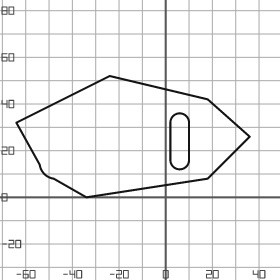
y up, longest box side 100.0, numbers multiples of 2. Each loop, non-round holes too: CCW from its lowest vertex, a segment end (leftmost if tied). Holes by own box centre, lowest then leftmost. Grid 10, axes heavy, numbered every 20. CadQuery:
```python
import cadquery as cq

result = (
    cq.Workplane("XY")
    .moveTo(-34.0, 0.0)
    .lineTo(18.0, 8.0)
    .lineTo(36.0, 26.0)
    .lineTo(18.0, 42.0)
    .lineTo(-24.0, 52.0)
    .lineTo(-64.0, 32.0)
    .lineTo(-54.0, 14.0)
    .threePointArc((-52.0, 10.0), (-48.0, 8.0))
    .close()
    .moveTo(2.0, 16.0)
    .threePointArc((6.0, 12.0), (10.0, 16.0))
    .lineTo(10.0, 32.0)
    .threePointArc((6.0, 36.0), (2.0, 32.0))
    .close()
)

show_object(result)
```